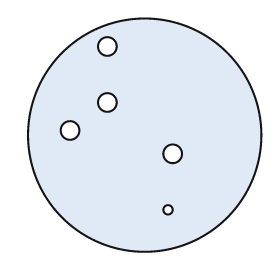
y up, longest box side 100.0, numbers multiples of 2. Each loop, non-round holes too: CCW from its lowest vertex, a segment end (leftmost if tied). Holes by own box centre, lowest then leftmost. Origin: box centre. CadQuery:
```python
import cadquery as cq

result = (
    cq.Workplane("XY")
    .moveTo(0.0, 0.0)
    .circle(50.0)
    .moveTo(10.0, -32.0)
    .circle(2.0)
    .moveTo(12.0, -8.0)
    .circle(4.0)
    .moveTo(-32.0, 2.0)
    .circle(4.0)
    .moveTo(-16.0, 14.0)
    .circle(4.0)
    .moveTo(-16.0, 38.0)
    .circle(4.0)
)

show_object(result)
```